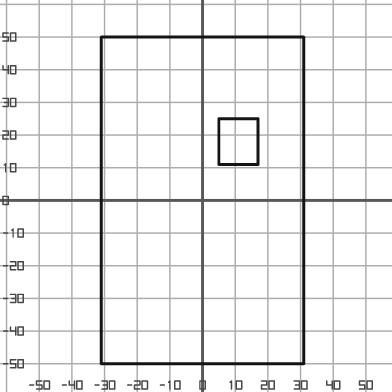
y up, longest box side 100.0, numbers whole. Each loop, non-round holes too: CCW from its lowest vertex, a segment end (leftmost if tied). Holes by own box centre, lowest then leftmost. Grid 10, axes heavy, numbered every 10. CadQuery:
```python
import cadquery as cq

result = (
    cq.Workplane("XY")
    .moveTo(-31.0, -50.0)
    .lineTo(31.0, -50.0)
    .lineTo(31.0, 50.0)
    .lineTo(-31.0, 50.0)
    .close()
    .moveTo(5.0, 11.0)
    .lineTo(17.0, 11.0)
    .lineTo(17.0, 25.0)
    .lineTo(5.0, 25.0)
    .close()
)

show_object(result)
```